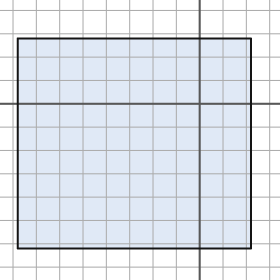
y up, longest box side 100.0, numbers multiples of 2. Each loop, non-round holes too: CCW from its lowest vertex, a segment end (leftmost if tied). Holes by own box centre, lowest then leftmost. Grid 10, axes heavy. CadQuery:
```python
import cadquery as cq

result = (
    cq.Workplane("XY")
    .moveTo(-78.0, -62.0)
    .lineTo(22.0, -62.0)
    .lineTo(22.0, 28.0)
    .lineTo(-78.0, 28.0)
    .close()
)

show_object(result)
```